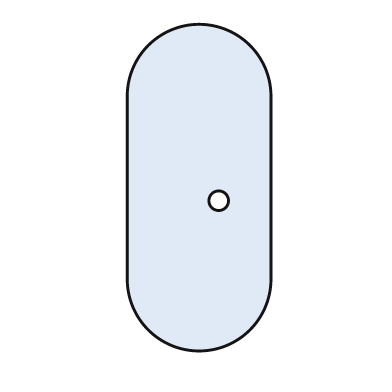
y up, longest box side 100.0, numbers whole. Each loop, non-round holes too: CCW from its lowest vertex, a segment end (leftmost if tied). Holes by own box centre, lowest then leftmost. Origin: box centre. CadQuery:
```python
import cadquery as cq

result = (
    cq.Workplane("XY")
    .moveTo(-22.0, -28.0)
    .threePointArc((0.0, -50.0), (22.0, -28.0))
    .lineTo(22.0, 28.0)
    .threePointArc((0.0, 50.0), (-22.0, 28.0))
    .close()
    .moveTo(6.0, -4.0)
    .circle(3.0)
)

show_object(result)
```